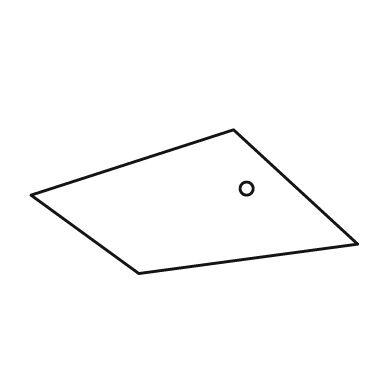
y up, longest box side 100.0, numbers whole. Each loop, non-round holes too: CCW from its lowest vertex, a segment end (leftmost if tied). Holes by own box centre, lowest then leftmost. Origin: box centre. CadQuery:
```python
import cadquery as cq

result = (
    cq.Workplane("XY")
    .moveTo(-17.0, -22.0)
    .lineTo(50.0, -13.0)
    .lineTo(12.0, 22.0)
    .lineTo(-50.0, 2.0)
    .close()
    .moveTo(16.0, 4.0)
    .circle(2.0)
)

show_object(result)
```